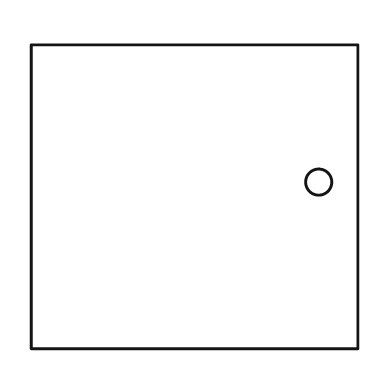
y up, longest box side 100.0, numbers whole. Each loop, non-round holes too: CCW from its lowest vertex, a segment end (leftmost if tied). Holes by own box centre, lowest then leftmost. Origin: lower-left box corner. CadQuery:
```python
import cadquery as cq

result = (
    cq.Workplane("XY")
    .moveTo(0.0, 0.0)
    .lineTo(100.0, 0.0)
    .lineTo(100.0, 93.0)
    .lineTo(0.0, 93.0)
    .close()
    .moveTo(88.0, 51.0)
    .circle(4.0)
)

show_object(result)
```